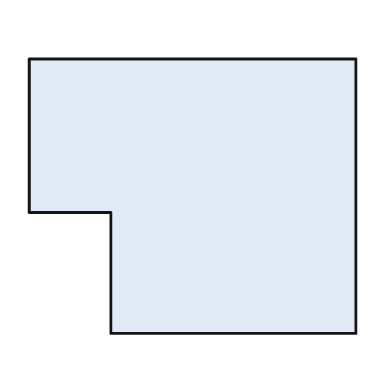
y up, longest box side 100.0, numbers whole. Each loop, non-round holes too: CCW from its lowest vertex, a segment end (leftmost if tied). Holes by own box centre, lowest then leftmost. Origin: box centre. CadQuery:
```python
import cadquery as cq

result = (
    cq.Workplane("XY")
    .moveTo(-25.0, -42.0)
    .lineTo(50.0, -42.0)
    .lineTo(50.0, 42.0)
    .lineTo(-50.0, 42.0)
    .lineTo(-50.0, -5.0)
    .lineTo(-25.0, -5.0)
    .close()
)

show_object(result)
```